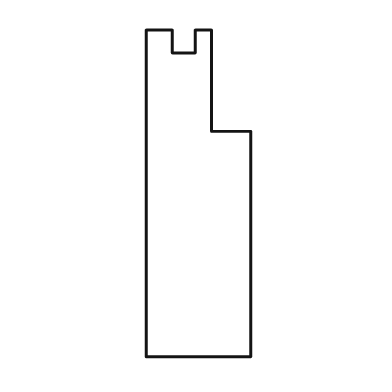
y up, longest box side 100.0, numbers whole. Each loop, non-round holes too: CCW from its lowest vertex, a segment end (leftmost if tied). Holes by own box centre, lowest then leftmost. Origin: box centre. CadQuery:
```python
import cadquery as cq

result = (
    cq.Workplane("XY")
    .moveTo(-16.0, -50.0)
    .lineTo(16.0, -50.0)
    .lineTo(16.0, 19.0)
    .lineTo(4.0, 19.0)
    .lineTo(4.0, 50.0)
    .lineTo(-1.0, 50.0)
    .lineTo(-1.0, 43.0)
    .lineTo(-8.0, 43.0)
    .lineTo(-8.0, 50.0)
    .lineTo(-16.0, 50.0)
    .close()
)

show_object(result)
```